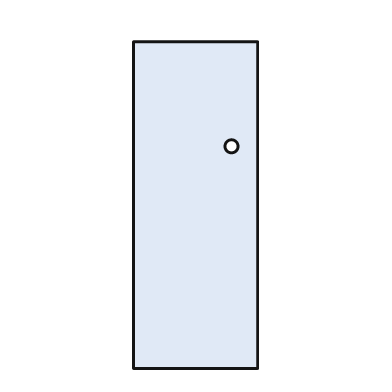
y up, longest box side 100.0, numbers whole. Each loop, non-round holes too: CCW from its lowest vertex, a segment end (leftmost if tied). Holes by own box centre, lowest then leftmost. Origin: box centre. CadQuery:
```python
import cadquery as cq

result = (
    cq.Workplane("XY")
    .moveTo(-19.0, -50.0)
    .lineTo(19.0, -50.0)
    .lineTo(19.0, 50.0)
    .lineTo(-19.0, 50.0)
    .close()
    .moveTo(11.0, 18.0)
    .circle(2.0)
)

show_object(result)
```